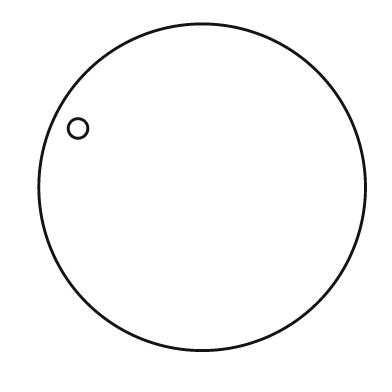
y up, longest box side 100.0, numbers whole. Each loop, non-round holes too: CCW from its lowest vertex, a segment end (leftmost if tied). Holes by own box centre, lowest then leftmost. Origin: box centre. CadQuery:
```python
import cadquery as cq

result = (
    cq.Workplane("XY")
    .moveTo(0.0, 0.0)
    .circle(50.0)
    .moveTo(-38.0, 18.0)
    .circle(3.0)
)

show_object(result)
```